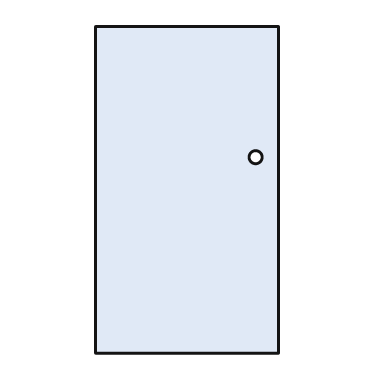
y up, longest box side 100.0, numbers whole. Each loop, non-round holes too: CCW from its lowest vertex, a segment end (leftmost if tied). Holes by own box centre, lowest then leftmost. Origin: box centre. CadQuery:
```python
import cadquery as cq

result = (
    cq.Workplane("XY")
    .moveTo(-28.0, -50.0)
    .lineTo(28.0, -50.0)
    .lineTo(28.0, 50.0)
    .lineTo(-28.0, 50.0)
    .close()
    .moveTo(21.0, 10.0)
    .circle(2.0)
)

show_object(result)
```